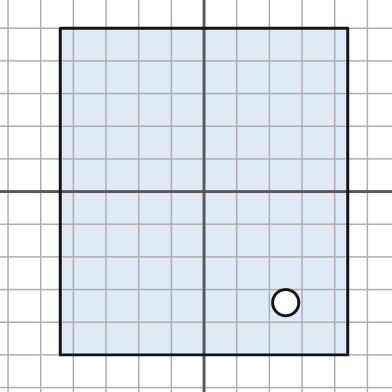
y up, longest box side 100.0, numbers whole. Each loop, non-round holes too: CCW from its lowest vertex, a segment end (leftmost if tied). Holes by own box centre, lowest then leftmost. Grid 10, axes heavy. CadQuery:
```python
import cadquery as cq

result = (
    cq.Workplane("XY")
    .moveTo(-44.0, -50.0)
    .lineTo(44.0, -50.0)
    .lineTo(44.0, 50.0)
    .lineTo(-44.0, 50.0)
    .close()
    .moveTo(25.0, -34.0)
    .circle(4.0)
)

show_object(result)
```